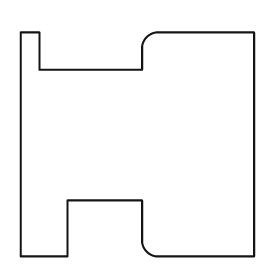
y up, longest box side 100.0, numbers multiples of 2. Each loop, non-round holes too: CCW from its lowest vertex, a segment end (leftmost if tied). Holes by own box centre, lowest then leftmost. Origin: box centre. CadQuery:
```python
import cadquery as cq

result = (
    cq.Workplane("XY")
    .moveTo(-50.0, -48.0)
    .lineTo(-30.0, -48.0)
    .lineTo(-30.0, -24.0)
    .lineTo(2.0, -24.0)
    .lineTo(2.0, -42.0)
    .threePointArc((4.0, -46.0), (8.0, -48.0))
    .lineTo(50.0, -48.0)
    .lineTo(50.0, 48.0)
    .lineTo(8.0, 48.0)
    .threePointArc((4.0, 46.0), (2.0, 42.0))
    .lineTo(2.0, 32.0)
    .lineTo(-42.0, 32.0)
    .lineTo(-42.0, 48.0)
    .lineTo(-50.0, 48.0)
    .close()
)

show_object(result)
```